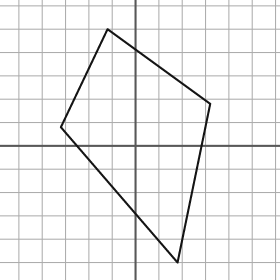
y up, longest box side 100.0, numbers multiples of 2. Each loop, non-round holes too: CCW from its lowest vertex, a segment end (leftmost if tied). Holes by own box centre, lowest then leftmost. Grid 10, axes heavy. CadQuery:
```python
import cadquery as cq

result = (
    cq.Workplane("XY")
    .moveTo(18.0, -50.0)
    .lineTo(32.0, 18.0)
    .lineTo(-12.0, 50.0)
    .lineTo(-32.0, 8.0)
    .close()
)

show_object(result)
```